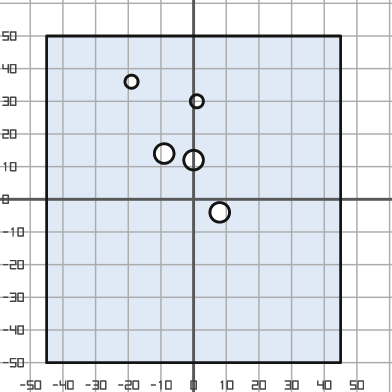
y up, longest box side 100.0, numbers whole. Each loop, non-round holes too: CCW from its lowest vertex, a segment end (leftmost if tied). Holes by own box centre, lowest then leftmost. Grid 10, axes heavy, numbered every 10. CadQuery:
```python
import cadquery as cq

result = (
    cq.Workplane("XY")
    .moveTo(-45.0, -50.0)
    .lineTo(45.0, -50.0)
    .lineTo(45.0, 50.0)
    .lineTo(-45.0, 50.0)
    .close()
    .moveTo(8.0, -4.0)
    .circle(3.0)
    .moveTo(0.0, 12.0)
    .circle(3.0)
    .moveTo(-9.0, 14.0)
    .circle(3.0)
    .moveTo(1.0, 30.0)
    .circle(2.0)
    .moveTo(-19.0, 36.0)
    .circle(2.0)
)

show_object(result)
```